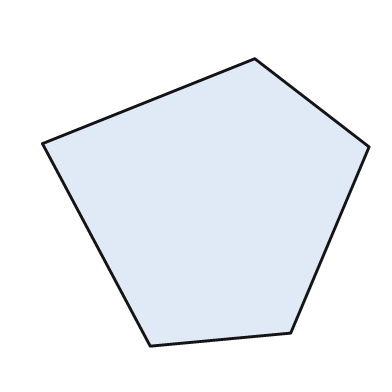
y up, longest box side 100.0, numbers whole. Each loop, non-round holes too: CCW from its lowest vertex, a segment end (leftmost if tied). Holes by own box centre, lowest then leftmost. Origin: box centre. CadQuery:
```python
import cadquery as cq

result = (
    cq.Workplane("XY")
    .moveTo(-17.0, -44.0)
    .lineTo(26.0, -40.0)
    .lineTo(50.0, 17.0)
    .lineTo(15.0, 44.0)
    .lineTo(-50.0, 18.0)
    .close()
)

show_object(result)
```